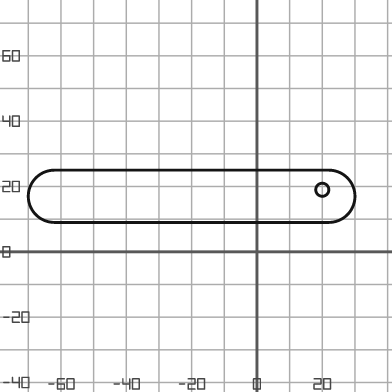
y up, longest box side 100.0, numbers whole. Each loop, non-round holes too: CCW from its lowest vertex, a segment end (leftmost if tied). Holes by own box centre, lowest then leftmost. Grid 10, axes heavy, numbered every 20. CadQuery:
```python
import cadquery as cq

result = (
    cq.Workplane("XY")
    .moveTo(-62.0, 9.0)
    .lineTo(22.0, 9.0)
    .threePointArc((30.0, 17.0), (22.0, 25.0))
    .lineTo(-62.0, 25.0)
    .threePointArc((-70.0, 17.0), (-62.0, 9.0))
    .close()
    .moveTo(20.0, 19.0)
    .circle(2.0)
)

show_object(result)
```